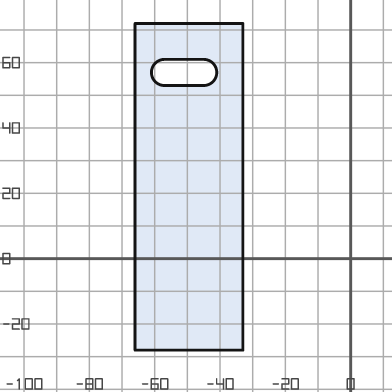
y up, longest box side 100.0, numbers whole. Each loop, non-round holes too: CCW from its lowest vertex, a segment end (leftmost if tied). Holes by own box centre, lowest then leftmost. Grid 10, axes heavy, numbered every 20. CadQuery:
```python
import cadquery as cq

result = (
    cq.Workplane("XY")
    .moveTo(-66.0, -28.0)
    .lineTo(-33.0, -28.0)
    .lineTo(-33.0, 72.0)
    .lineTo(-66.0, 72.0)
    .close()
    .moveTo(-57.0, 53.0)
    .lineTo(-45.0, 53.0)
    .threePointArc((-41.0, 57.0), (-45.0, 61.0))
    .lineTo(-57.0, 61.0)
    .threePointArc((-61.0, 57.0), (-57.0, 53.0))
    .close()
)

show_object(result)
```